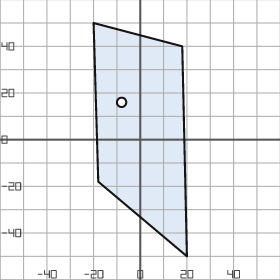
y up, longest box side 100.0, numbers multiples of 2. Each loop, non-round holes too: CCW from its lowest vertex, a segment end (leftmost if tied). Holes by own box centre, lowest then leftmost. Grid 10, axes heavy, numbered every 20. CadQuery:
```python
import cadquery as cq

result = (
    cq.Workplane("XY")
    .moveTo(20.0, -50.0)
    .lineTo(18.0, 40.0)
    .lineTo(-20.0, 50.0)
    .lineTo(-18.0, -18.0)
    .close()
    .moveTo(-8.0, 16.0)
    .circle(2.0)
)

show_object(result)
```